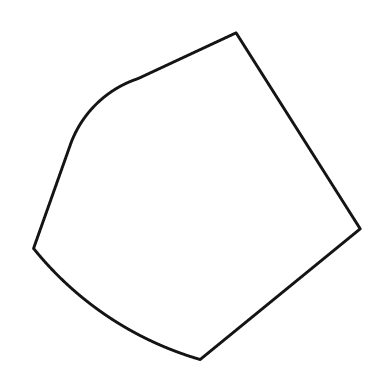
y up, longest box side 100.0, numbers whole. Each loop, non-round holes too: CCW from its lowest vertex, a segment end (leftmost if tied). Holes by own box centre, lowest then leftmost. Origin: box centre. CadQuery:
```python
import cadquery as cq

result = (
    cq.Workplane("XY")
    .moveTo(1.0, -50.0)
    .lineTo(50.0, -10.0)
    .lineTo(12.0, 50.0)
    .lineTo(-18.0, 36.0)
    .threePointArc((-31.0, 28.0), (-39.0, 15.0))
    .lineTo(-50.0, -16.0)
    .threePointArc((-27.0, -37.0), (1.0, -50.0))
    .close()
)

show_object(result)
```